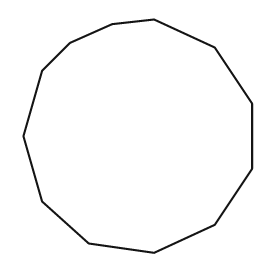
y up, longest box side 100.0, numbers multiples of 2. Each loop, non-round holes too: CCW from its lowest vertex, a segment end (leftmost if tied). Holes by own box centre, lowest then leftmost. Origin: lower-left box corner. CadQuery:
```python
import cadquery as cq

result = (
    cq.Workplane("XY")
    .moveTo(56.0, 0.0)
    .lineTo(82.0, 12.0)
    .lineTo(98.0, 36.0)
    .lineTo(98.0, 64.0)
    .lineTo(82.0, 88.0)
    .lineTo(56.0, 100.0)
    .lineTo(38.0, 98.0)
    .lineTo(20.0, 90.0)
    .lineTo(8.0, 78.0)
    .lineTo(0.0, 50.0)
    .lineTo(8.0, 22.0)
    .lineTo(28.0, 4.0)
    .close()
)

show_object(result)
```